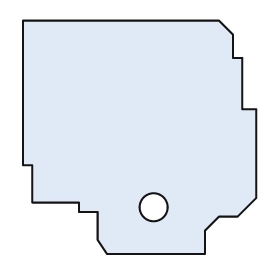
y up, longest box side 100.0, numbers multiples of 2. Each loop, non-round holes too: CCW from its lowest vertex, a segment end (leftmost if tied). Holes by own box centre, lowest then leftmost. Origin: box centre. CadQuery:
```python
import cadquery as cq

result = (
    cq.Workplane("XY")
    .moveTo(-14.0, -50.0)
    .lineTo(28.0, -50.0)
    .lineTo(28.0, -40.0)
    .lineTo(34.0, -34.0)
    .lineTo(42.0, -34.0)
    .lineTo(50.0, -26.0)
    .lineTo(50.0, 12.0)
    .lineTo(44.0, 12.0)
    .lineTo(44.0, 34.0)
    .lineTo(40.0, 34.0)
    .lineTo(40.0, 44.0)
    .lineTo(34.0, 50.0)
    .lineTo(-50.0, 50.0)
    .lineTo(-50.0, -12.0)
    .lineTo(-46.0, -12.0)
    .lineTo(-46.0, -28.0)
    .lineTo(-26.0, -28.0)
    .lineTo(-26.0, -32.0)
    .lineTo(-18.0, -32.0)
    .lineTo(-18.0, -44.0)
    .close()
    .moveTo(6.0, -30.0)
    .circle(6.0)
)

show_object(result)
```